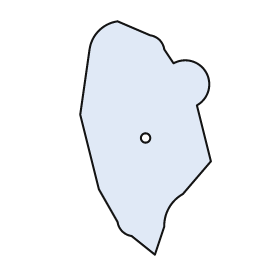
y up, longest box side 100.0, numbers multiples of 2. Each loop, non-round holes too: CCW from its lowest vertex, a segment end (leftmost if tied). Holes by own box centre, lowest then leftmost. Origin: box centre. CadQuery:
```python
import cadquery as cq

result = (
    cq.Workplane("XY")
    .moveTo(4.0, -50.0)
    .lineTo(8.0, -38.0)
    .threePointArc((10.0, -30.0), (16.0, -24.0))
    .lineTo(28.0, -10.0)
    .lineTo(22.0, 14.0)
    .threePointArc((26.0, 28.0), (12.0, 32.0))
    .lineTo(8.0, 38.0)
    .threePointArc((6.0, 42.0), (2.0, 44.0))
    .lineTo(-12.0, 50.0)
    .threePointArc((-20.0, 46.0), (-24.0, 38.0))
    .lineTo(-28.0, 10.0)
    .lineTo(-20.0, -22.0)
    .lineTo(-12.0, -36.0)
    .threePointArc((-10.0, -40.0), (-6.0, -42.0))
    .close()
    .moveTo(0.0, 0.0)
    .circle(2.0)
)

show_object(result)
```